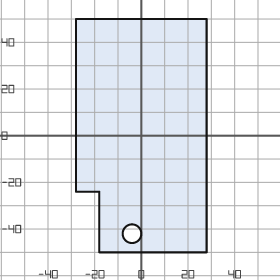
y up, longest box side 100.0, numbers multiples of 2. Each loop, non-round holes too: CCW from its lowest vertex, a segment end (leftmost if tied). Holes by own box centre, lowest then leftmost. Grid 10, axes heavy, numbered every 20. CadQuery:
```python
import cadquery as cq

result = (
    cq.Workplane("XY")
    .moveTo(-18.0, -50.0)
    .lineTo(28.0, -50.0)
    .lineTo(28.0, 50.0)
    .lineTo(-28.0, 50.0)
    .lineTo(-28.0, -24.0)
    .lineTo(-18.0, -24.0)
    .close()
    .moveTo(-4.0, -42.0)
    .circle(4.0)
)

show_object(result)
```